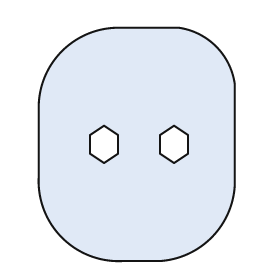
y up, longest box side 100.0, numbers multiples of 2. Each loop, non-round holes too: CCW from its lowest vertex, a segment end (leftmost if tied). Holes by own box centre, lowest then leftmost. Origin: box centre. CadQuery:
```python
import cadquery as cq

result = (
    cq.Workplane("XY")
    .moveTo(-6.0, -50.0)
    .lineTo(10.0, -50.0)
    .threePointArc((32.0, -40.0), (42.0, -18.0))
    .lineTo(42.0, 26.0)
    .threePointArc((34.0, 42.0), (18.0, 50.0))
    .lineTo(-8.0, 50.0)
    .threePointArc((-32.0, 40.0), (-42.0, 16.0))
    .lineTo(-42.0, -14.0)
    .threePointArc((-32.0, -40.0), (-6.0, -50.0))
    .close()
    .moveTo(-14.0, -8.0)
    .lineTo(-8.0, -4.0)
    .lineTo(-8.0, 4.0)
    .lineTo(-14.0, 8.0)
    .lineTo(-20.0, 4.0)
    .lineTo(-20.0, -4.0)
    .close()
    .moveTo(16.0, -8.0)
    .lineTo(22.0, -4.0)
    .lineTo(22.0, 4.0)
    .lineTo(16.0, 8.0)
    .lineTo(10.0, 4.0)
    .lineTo(10.0, -4.0)
    .close()
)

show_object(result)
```